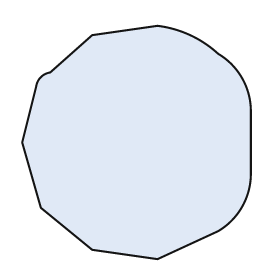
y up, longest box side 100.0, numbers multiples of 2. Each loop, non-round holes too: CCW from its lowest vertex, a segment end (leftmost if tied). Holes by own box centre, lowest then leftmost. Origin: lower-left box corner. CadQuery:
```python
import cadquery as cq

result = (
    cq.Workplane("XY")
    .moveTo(58.0, 0.0)
    .lineTo(84.0, 12.0)
    .threePointArc((94.0, 22.0), (98.0, 36.0))
    .lineTo(98.0, 64.0)
    .threePointArc((94.0, 78.0), (84.0, 88.0))
    .threePointArc((72.0, 96.0), (58.0, 100.0))
    .lineTo(30.0, 96.0)
    .lineTo(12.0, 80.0)
    .threePointArc((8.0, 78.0), (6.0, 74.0))
    .lineTo(0.0, 50.0)
    .lineTo(8.0, 22.0)
    .lineTo(30.0, 4.0)
    .close()
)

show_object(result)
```